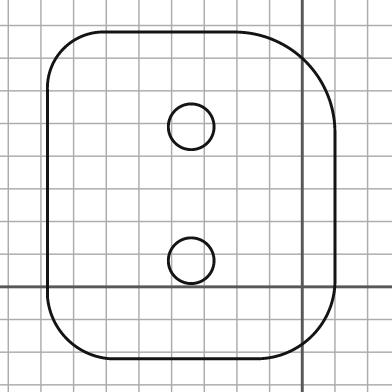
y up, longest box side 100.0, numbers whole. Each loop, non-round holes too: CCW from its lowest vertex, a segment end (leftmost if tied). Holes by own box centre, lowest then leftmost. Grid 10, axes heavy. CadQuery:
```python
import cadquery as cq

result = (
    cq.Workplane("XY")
    .moveTo(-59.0, -22.0)
    .lineTo(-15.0, -22.0)
    .threePointArc((3.0, -15.0), (10.0, 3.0))
    .lineTo(10.0, 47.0)
    .threePointArc((1.0, 69.0), (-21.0, 78.0))
    .lineTo(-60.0, 78.0)
    .threePointArc((-73.0, 73.0), (-78.0, 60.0))
    .lineTo(-78.0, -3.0)
    .threePointArc((-72.0, -16.0), (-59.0, -22.0))
    .close()
    .moveTo(-34.0, 8.0)
    .circle(7.0)
    .moveTo(-34.0, 49.0)
    .circle(7.0)
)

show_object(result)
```